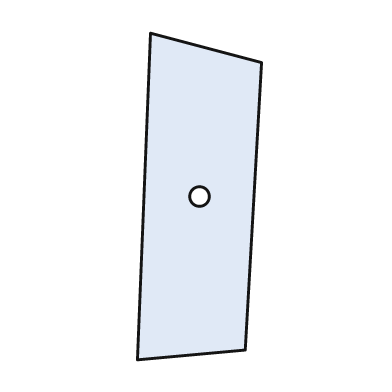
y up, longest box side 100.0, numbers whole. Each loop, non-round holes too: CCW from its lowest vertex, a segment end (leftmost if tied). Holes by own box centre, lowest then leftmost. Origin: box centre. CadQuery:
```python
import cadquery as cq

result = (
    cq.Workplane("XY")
    .moveTo(-19.0, -50.0)
    .lineTo(14.0, -47.0)
    .lineTo(19.0, 41.0)
    .lineTo(-15.0, 50.0)
    .close()
    .moveTo(0.0, 0.0)
    .circle(3.0)
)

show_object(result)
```